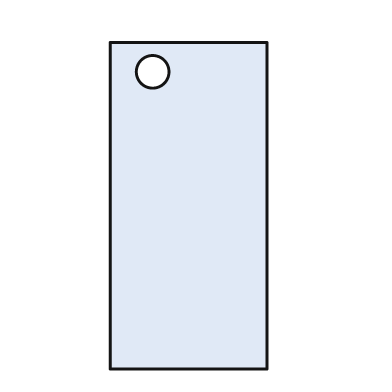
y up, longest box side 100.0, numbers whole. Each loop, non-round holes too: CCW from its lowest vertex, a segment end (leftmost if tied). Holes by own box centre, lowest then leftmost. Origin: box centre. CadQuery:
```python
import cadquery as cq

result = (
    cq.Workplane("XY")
    .moveTo(-24.0, -50.0)
    .lineTo(24.0, -50.0)
    .lineTo(24.0, 50.0)
    .lineTo(-24.0, 50.0)
    .close()
    .moveTo(-11.0, 41.0)
    .circle(5.0)
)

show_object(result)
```